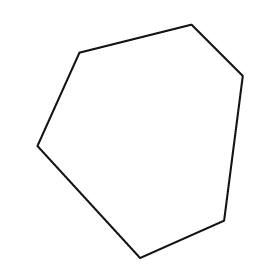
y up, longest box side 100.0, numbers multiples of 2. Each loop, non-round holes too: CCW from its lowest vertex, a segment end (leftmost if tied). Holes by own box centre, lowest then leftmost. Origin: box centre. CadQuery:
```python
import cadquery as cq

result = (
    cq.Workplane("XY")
    .moveTo(0.0, -50.0)
    .lineTo(36.0, -34.0)
    .lineTo(44.0, 28.0)
    .lineTo(22.0, 50.0)
    .lineTo(-26.0, 38.0)
    .lineTo(-44.0, -2.0)
    .close()
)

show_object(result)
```